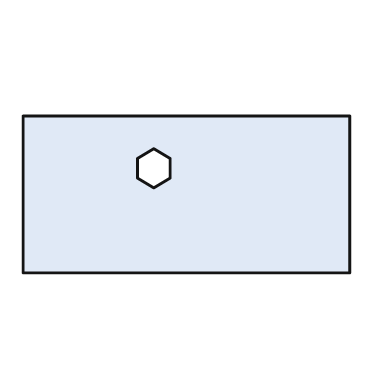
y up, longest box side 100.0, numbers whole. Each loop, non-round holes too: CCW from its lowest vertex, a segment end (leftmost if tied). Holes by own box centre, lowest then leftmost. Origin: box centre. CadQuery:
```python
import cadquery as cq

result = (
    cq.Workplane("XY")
    .moveTo(-50.0, -24.0)
    .lineTo(50.0, -24.0)
    .lineTo(50.0, 24.0)
    .lineTo(-50.0, 24.0)
    .close()
    .moveTo(-10.0, 2.0)
    .lineTo(-5.0, 5.0)
    .lineTo(-5.0, 11.0)
    .lineTo(-10.0, 14.0)
    .lineTo(-15.0, 11.0)
    .lineTo(-15.0, 5.0)
    .close()
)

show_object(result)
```